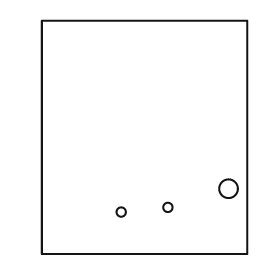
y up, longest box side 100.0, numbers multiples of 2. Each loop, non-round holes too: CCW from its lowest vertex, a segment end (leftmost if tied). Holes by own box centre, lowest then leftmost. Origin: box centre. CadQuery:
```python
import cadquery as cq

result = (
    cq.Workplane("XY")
    .moveTo(-44.0, -50.0)
    .lineTo(44.0, -50.0)
    .lineTo(44.0, 50.0)
    .lineTo(-44.0, 50.0)
    .close()
    .moveTo(-10.0, -32.0)
    .circle(2.0)
    .moveTo(10.0, -30.0)
    .circle(2.0)
    .moveTo(36.0, -22.0)
    .circle(4.0)
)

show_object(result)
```